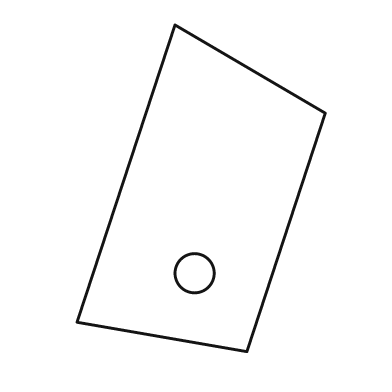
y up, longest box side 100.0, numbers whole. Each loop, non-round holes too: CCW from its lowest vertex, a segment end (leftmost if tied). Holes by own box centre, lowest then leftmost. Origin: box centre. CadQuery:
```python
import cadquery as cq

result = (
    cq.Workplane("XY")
    .moveTo(14.0, -50.0)
    .lineTo(38.0, 23.0)
    .lineTo(-8.0, 50.0)
    .lineTo(-38.0, -41.0)
    .close()
    .moveTo(-2.0, -26.0)
    .circle(6.0)
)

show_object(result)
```